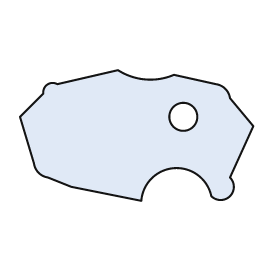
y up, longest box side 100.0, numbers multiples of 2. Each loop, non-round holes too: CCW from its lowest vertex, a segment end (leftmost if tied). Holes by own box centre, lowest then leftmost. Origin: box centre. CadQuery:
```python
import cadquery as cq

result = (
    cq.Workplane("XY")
    .moveTo(2.0, -28.0)
    .threePointArc((16.0, -14.0), (32.0, -26.0))
    .threePointArc((40.0, -26.0), (40.0, -18.0))
    .lineTo(50.0, 4.0)
    .lineTo(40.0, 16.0)
    .threePointArc((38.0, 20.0), (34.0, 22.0))
    .lineTo(16.0, 26.0)
    .threePointArc((4.0, 24.0), (-8.0, 28.0))
    .lineTo(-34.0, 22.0)
    .threePointArc((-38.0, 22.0), (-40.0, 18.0))
    .lineTo(-50.0, 8.0)
    .lineTo(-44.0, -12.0)
    .threePointArc((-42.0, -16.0), (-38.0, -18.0))
    .lineTo(-28.0, -22.0)
    .close()
    .moveTo(20.0, 8.0)
    .circle(6.0)
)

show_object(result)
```